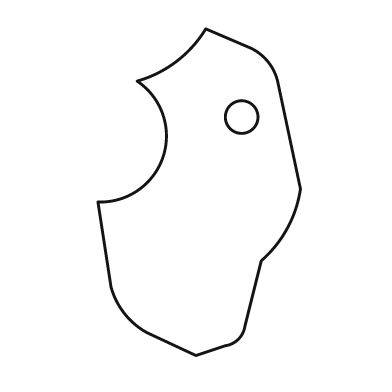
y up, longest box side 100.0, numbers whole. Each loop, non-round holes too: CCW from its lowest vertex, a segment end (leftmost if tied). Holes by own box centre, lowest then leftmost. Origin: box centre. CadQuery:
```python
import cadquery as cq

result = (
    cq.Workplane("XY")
    .moveTo(-1.0, -50.0)
    .lineTo(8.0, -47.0)
    .threePointArc((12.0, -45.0), (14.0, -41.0))
    .lineTo(19.0, -21.0)
    .threePointArc((27.0, -11.0), (31.0, 1.0))
    .lineTo(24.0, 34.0)
    .threePointArc((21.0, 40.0), (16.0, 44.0))
    .lineTo(2.0, 50.0)
    .threePointArc((-7.0, 40.0), (-19.0, 34.0))
    .threePointArc((-11.0, 11.0), (-31.0, -3.0))
    .lineTo(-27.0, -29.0)
    .threePointArc((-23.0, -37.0), (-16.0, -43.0))
    .close()
    .moveTo(13.0, 23.0)
    .circle(5.0)
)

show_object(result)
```